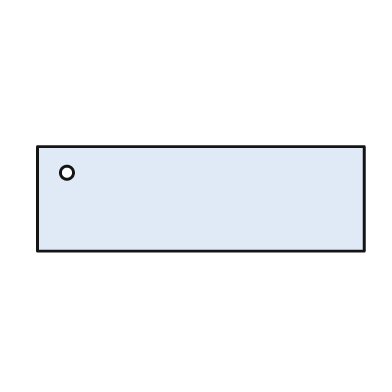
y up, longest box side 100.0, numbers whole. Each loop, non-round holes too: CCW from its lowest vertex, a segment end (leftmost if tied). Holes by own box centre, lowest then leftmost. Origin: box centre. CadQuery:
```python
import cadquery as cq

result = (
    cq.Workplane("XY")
    .moveTo(-50.0, -16.0)
    .lineTo(50.0, -16.0)
    .lineTo(50.0, 16.0)
    .lineTo(-50.0, 16.0)
    .close()
    .moveTo(-41.0, 8.0)
    .circle(2.0)
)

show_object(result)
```